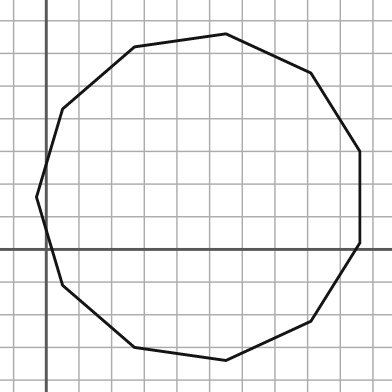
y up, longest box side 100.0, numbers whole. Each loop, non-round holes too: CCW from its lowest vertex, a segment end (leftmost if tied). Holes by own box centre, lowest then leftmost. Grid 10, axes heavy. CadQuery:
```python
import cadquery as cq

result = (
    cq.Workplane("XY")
    .moveTo(55.0, -34.0)
    .lineTo(81.0, -22.0)
    .lineTo(96.0, 2.0)
    .lineTo(96.0, 30.0)
    .lineTo(81.0, 54.0)
    .lineTo(55.0, 66.0)
    .lineTo(27.0, 62.0)
    .lineTo(5.0, 43.0)
    .lineTo(-3.0, 16.0)
    .lineTo(5.0, -11.0)
    .lineTo(27.0, -30.0)
    .close()
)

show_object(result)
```